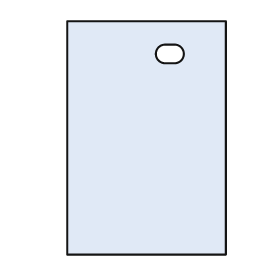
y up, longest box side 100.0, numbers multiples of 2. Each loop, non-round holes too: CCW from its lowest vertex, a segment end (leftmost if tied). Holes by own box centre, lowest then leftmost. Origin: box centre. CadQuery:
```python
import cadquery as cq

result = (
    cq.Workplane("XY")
    .moveTo(-34.0, -50.0)
    .lineTo(34.0, -50.0)
    .lineTo(34.0, 50.0)
    .lineTo(-34.0, 50.0)
    .close()
    .moveTo(8.0, 32.0)
    .lineTo(12.0, 32.0)
    .threePointArc((16.0, 36.0), (12.0, 40.0))
    .lineTo(8.0, 40.0)
    .threePointArc((4.0, 36.0), (8.0, 32.0))
    .close()
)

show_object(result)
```